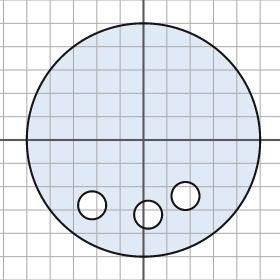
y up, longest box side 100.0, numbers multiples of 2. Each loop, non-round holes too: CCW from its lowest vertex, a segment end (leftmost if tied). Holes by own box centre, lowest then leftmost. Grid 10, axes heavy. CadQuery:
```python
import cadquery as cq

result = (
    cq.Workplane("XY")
    .moveTo(0.0, 0.0)
    .circle(50.0)
    .moveTo(2.0, -32.0)
    .circle(6.0)
    .moveTo(-22.0, -28.0)
    .circle(6.0)
    .moveTo(18.0, -24.0)
    .circle(6.0)
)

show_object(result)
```